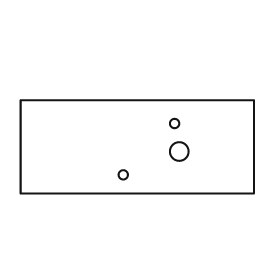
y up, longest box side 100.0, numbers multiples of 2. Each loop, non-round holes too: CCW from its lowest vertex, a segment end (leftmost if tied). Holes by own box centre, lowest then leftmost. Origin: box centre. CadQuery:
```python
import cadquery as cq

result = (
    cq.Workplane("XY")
    .moveTo(-50.0, -20.0)
    .lineTo(50.0, -20.0)
    .lineTo(50.0, 20.0)
    .lineTo(-50.0, 20.0)
    .close()
    .moveTo(-6.0, -12.0)
    .circle(2.0)
    .moveTo(18.0, -2.0)
    .circle(4.0)
    .moveTo(16.0, 10.0)
    .circle(2.0)
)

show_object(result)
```